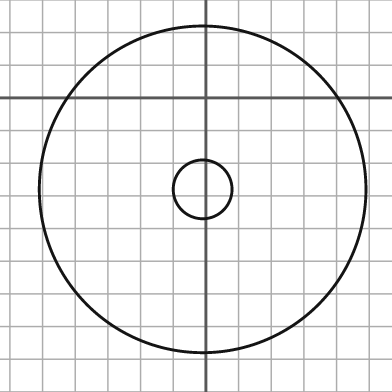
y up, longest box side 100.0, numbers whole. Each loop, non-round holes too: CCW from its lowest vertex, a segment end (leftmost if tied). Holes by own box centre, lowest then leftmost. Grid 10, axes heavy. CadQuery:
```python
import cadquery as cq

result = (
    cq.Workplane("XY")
    .moveTo(-1.0, -28.0)
    .circle(50.0)
    .moveTo(-1.0, -28.0)
    .circle(9.0)
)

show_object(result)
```